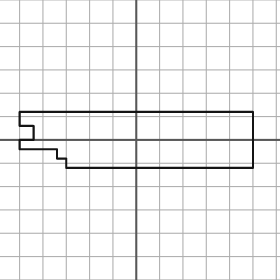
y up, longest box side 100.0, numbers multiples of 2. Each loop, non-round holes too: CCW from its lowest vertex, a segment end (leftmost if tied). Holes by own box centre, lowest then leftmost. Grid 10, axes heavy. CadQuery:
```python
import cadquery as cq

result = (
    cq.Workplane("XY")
    .moveTo(-30.0, -12.0)
    .lineTo(50.0, -12.0)
    .lineTo(50.0, 12.0)
    .lineTo(-50.0, 12.0)
    .lineTo(-50.0, 6.0)
    .lineTo(-44.0, 6.0)
    .lineTo(-44.0, 0.0)
    .lineTo(-50.0, 0.0)
    .lineTo(-50.0, -4.0)
    .lineTo(-34.0, -4.0)
    .lineTo(-34.0, -8.0)
    .lineTo(-30.0, -8.0)
    .close()
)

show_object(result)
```